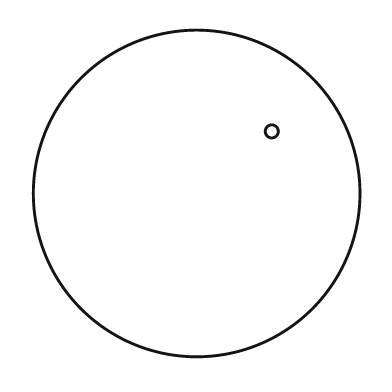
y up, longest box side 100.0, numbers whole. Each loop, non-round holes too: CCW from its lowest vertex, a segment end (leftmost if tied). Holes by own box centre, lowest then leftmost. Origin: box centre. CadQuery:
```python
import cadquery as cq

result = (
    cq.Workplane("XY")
    .moveTo(0.0, 0.0)
    .circle(50.0)
    .moveTo(23.0, 19.0)
    .circle(2.0)
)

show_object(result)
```